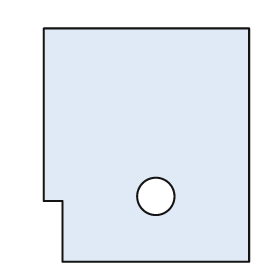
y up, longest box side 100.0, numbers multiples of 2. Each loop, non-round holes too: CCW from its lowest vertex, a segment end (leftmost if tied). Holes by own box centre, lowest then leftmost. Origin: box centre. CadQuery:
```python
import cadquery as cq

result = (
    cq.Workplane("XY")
    .moveTo(-36.0, -50.0)
    .lineTo(44.0, -50.0)
    .lineTo(44.0, 50.0)
    .lineTo(-44.0, 50.0)
    .lineTo(-44.0, -24.0)
    .lineTo(-36.0, -24.0)
    .close()
    .moveTo(4.0, -22.0)
    .circle(8.0)
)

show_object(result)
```